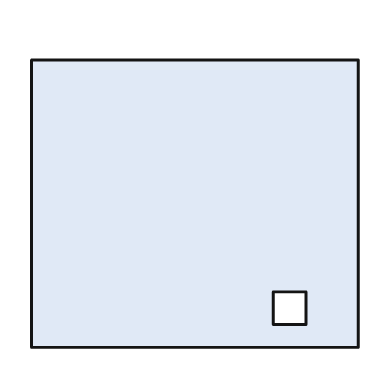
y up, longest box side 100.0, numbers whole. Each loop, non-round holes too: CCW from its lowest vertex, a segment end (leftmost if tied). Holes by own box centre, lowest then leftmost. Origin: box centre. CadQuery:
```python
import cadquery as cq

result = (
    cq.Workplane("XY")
    .moveTo(-50.0, -44.0)
    .lineTo(50.0, -44.0)
    .lineTo(50.0, 44.0)
    .lineTo(-50.0, 44.0)
    .close()
    .moveTo(24.0, -37.0)
    .lineTo(34.0, -37.0)
    .lineTo(34.0, -27.0)
    .lineTo(24.0, -27.0)
    .close()
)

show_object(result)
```